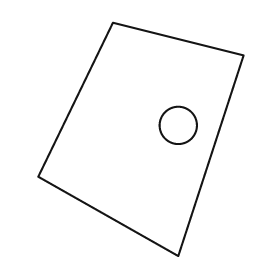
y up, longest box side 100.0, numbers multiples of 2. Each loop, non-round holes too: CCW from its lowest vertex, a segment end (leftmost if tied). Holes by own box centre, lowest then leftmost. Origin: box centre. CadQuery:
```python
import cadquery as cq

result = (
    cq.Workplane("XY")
    .moveTo(16.0, -50.0)
    .lineTo(44.0, 36.0)
    .lineTo(-12.0, 50.0)
    .lineTo(-44.0, -16.0)
    .close()
    .moveTo(16.0, 6.0)
    .circle(8.0)
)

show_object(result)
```